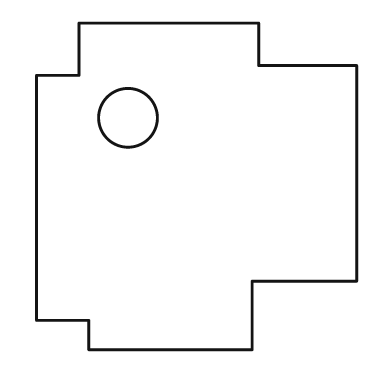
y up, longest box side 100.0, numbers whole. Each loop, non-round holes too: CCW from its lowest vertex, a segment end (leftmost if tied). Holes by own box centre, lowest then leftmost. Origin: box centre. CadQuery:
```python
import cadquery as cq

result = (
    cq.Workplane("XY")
    .moveTo(-33.0, -50.0)
    .lineTo(17.0, -50.0)
    .lineTo(17.0, -29.0)
    .lineTo(49.0, -29.0)
    .lineTo(49.0, 37.0)
    .lineTo(19.0, 37.0)
    .lineTo(19.0, 50.0)
    .lineTo(-36.0, 50.0)
    .lineTo(-36.0, 34.0)
    .lineTo(-49.0, 34.0)
    .lineTo(-49.0, -41.0)
    .lineTo(-33.0, -41.0)
    .close()
    .moveTo(-21.0, 21.0)
    .circle(9.0)
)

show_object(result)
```